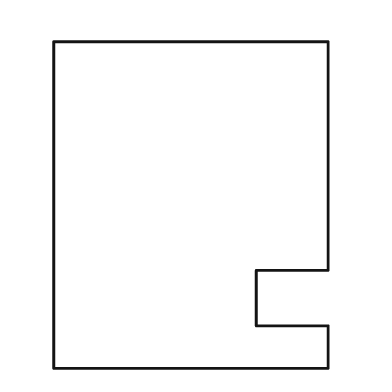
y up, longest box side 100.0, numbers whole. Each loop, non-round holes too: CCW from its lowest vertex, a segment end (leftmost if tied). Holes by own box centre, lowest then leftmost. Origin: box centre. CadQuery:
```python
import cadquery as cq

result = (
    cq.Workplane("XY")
    .moveTo(-42.0, -50.0)
    .lineTo(42.0, -50.0)
    .lineTo(42.0, -37.0)
    .lineTo(20.0, -37.0)
    .lineTo(20.0, -20.0)
    .lineTo(42.0, -20.0)
    .lineTo(42.0, 50.0)
    .lineTo(-42.0, 50.0)
    .close()
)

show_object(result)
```